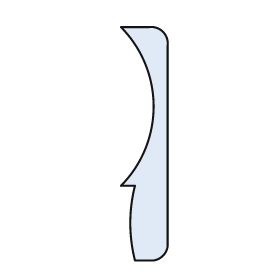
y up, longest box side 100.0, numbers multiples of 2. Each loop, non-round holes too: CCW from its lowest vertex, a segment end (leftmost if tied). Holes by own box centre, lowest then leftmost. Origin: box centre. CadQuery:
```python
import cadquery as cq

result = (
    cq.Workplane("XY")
    .moveTo(-4.0, -50.0)
    .lineTo(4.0, -50.0)
    .threePointArc((8.0, -48.0), (10.0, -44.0))
    .lineTo(10.0, 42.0)
    .threePointArc((8.0, 48.0), (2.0, 50.0))
    .lineTo(-10.0, 50.0)
    .threePointArc((4.0, 16.0), (-10.0, -18.0))
    .lineTo(-4.0, -18.0)
    .threePointArc((-6.0, -34.0), (-4.0, -50.0))
    .close()
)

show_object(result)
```